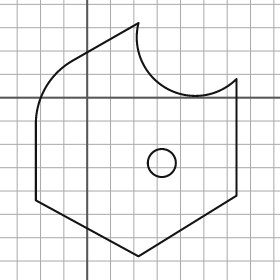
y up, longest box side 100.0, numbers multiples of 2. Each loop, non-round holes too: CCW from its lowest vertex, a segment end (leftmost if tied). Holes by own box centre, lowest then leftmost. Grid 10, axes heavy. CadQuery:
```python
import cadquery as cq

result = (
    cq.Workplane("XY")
    .moveTo(22.0, -68.0)
    .lineTo(64.0, -42.0)
    .lineTo(64.0, 8.0)
    .threePointArc((34.0, 4.0), (22.0, 32.0))
    .lineTo(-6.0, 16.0)
    .threePointArc((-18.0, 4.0), (-22.0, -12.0))
    .lineTo(-22.0, -44.0)
    .close()
    .moveTo(32.0, -28.0)
    .circle(6.0)
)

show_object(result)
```